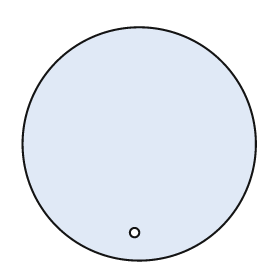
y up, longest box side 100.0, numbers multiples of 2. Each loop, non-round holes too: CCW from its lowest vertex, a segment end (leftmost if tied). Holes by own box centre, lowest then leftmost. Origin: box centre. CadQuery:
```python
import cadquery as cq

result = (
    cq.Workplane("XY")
    .moveTo(0.0, 0.0)
    .circle(50.0)
    .moveTo(-2.0, -38.0)
    .circle(2.0)
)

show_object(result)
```